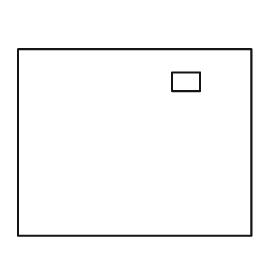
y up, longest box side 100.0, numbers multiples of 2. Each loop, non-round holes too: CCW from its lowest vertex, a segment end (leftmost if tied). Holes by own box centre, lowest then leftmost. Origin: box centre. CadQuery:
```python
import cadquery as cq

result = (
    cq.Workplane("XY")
    .moveTo(-50.0, -40.0)
    .lineTo(50.0, -40.0)
    .lineTo(50.0, 40.0)
    .lineTo(-50.0, 40.0)
    .close()
    .moveTo(16.0, 22.0)
    .lineTo(28.0, 22.0)
    .lineTo(28.0, 30.0)
    .lineTo(16.0, 30.0)
    .close()
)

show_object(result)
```